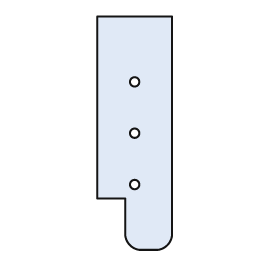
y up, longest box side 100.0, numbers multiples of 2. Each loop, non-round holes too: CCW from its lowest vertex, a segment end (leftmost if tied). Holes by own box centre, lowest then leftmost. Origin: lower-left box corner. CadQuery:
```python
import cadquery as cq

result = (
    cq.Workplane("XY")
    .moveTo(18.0, 0.0)
    .lineTo(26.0, 0.0)
    .threePointArc((30.0, 2.0), (32.0, 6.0))
    .lineTo(32.0, 100.0)
    .lineTo(0.0, 100.0)
    .lineTo(0.0, 22.0)
    .lineTo(12.0, 22.0)
    .lineTo(12.0, 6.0)
    .threePointArc((14.0, 2.0), (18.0, 0.0))
    .close()
    .moveTo(16.0, 28.0)
    .circle(2.0)
    .moveTo(16.0, 50.0)
    .circle(2.0)
    .moveTo(16.0, 72.0)
    .circle(2.0)
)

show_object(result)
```